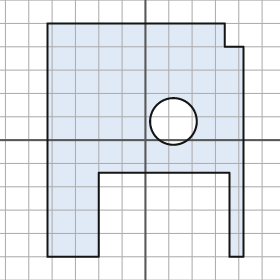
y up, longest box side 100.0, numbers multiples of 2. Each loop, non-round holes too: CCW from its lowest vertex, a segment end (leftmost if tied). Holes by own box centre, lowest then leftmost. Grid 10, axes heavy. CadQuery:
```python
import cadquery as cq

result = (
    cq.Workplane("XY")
    .moveTo(-42.0, -50.0)
    .lineTo(-20.0, -50.0)
    .lineTo(-20.0, -14.0)
    .lineTo(36.0, -14.0)
    .lineTo(36.0, -50.0)
    .lineTo(42.0, -50.0)
    .lineTo(42.0, 40.0)
    .lineTo(34.0, 40.0)
    .lineTo(34.0, 50.0)
    .lineTo(-42.0, 50.0)
    .close()
    .moveTo(12.0, 8.0)
    .circle(10.0)
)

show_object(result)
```